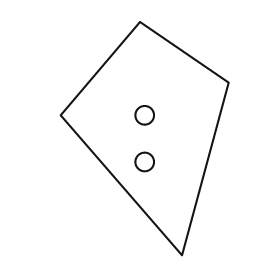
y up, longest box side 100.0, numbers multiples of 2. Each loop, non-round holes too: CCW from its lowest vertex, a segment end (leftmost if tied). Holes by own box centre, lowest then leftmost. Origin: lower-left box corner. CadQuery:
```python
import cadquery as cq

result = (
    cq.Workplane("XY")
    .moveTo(52.0, 0.0)
    .lineTo(72.0, 74.0)
    .lineTo(34.0, 100.0)
    .lineTo(0.0, 60.0)
    .close()
    .moveTo(36.0, 40.0)
    .circle(4.0)
    .moveTo(36.0, 60.0)
    .circle(4.0)
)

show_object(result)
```